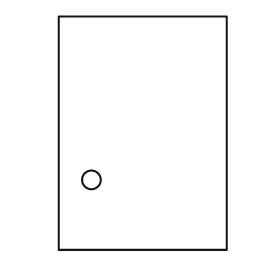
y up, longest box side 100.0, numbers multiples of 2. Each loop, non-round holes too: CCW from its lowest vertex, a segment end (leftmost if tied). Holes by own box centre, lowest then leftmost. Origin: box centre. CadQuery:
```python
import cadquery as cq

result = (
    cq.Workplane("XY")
    .moveTo(-36.0, -50.0)
    .lineTo(36.0, -50.0)
    .lineTo(36.0, 50.0)
    .lineTo(-36.0, 50.0)
    .close()
    .moveTo(-22.0, -20.0)
    .circle(4.0)
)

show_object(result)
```